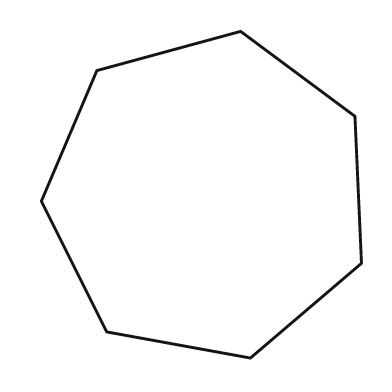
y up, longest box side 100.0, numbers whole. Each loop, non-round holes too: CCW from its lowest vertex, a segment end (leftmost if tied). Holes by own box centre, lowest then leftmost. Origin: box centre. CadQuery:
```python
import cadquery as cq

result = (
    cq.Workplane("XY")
    .moveTo(15.0, -50.0)
    .lineTo(49.0, -21.0)
    .lineTo(47.0, 24.0)
    .lineTo(12.0, 50.0)
    .lineTo(-32.0, 38.0)
    .lineTo(-49.0, -2.0)
    .lineTo(-29.0, -42.0)
    .close()
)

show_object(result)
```